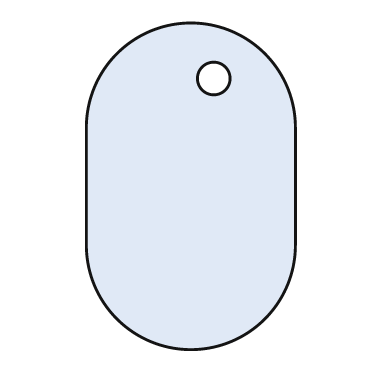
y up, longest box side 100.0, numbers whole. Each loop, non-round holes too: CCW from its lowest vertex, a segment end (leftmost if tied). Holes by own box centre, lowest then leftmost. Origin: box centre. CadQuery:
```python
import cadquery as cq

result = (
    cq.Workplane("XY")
    .moveTo(-32.0, -18.0)
    .threePointArc((0.0, -50.0), (32.0, -18.0))
    .lineTo(32.0, 18.0)
    .threePointArc((0.0, 50.0), (-32.0, 18.0))
    .close()
    .moveTo(7.0, 33.0)
    .circle(5.0)
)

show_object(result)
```